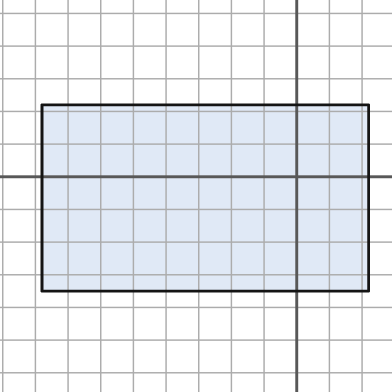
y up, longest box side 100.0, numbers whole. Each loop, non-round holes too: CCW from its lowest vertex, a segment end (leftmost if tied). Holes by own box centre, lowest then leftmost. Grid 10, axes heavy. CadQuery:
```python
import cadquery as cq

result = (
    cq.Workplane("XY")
    .moveTo(-78.0, -35.0)
    .lineTo(22.0, -35.0)
    .lineTo(22.0, 22.0)
    .lineTo(-78.0, 22.0)
    .close()
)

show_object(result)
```